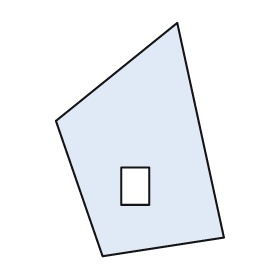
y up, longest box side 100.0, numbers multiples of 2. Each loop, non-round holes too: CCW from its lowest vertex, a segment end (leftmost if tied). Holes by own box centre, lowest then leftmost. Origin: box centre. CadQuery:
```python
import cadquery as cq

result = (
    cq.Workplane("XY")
    .moveTo(-16.0, -50.0)
    .lineTo(36.0, -42.0)
    .lineTo(16.0, 50.0)
    .lineTo(-36.0, 8.0)
    .close()
    .moveTo(-8.0, -28.0)
    .lineTo(4.0, -28.0)
    .lineTo(4.0, -12.0)
    .lineTo(-8.0, -12.0)
    .close()
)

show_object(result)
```